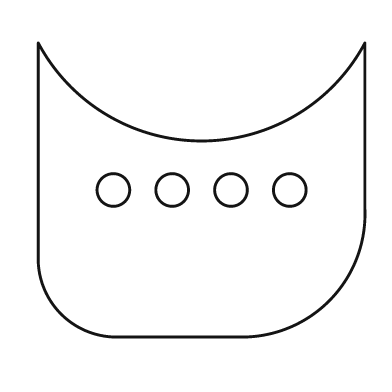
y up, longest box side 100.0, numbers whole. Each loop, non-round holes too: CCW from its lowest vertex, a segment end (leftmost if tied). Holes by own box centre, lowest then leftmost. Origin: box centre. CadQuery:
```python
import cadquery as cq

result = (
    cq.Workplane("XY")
    .moveTo(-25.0, -45.0)
    .lineTo(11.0, -45.0)
    .threePointArc((39.0, -34.0), (50.0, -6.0))
    .lineTo(50.0, 45.0)
    .threePointArc((0.0, 15.0), (-50.0, 45.0))
    .lineTo(-50.0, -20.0)
    .threePointArc((-43.0, -38.0), (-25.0, -45.0))
    .close()
    .moveTo(-27.0, 0.0)
    .circle(5.0)
    .moveTo(-9.0, 0.0)
    .circle(5.0)
    .moveTo(9.0, 0.0)
    .circle(5.0)
    .moveTo(27.0, 0.0)
    .circle(5.0)
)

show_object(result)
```